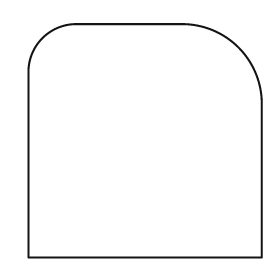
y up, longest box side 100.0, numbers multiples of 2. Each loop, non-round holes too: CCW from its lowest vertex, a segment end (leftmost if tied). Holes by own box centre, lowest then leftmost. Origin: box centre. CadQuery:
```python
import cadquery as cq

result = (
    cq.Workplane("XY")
    .moveTo(-50.0, -50.0)
    .lineTo(50.0, -50.0)
    .lineTo(50.0, 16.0)
    .threePointArc((40.0, 40.0), (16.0, 50.0))
    .lineTo(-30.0, 50.0)
    .threePointArc((-44.0, 44.0), (-50.0, 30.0))
    .close()
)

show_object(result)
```